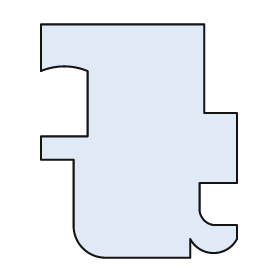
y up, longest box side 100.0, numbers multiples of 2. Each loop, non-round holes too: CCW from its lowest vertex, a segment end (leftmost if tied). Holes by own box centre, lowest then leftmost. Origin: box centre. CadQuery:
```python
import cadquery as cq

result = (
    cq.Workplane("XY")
    .moveTo(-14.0, -50.0)
    .lineTo(22.0, -50.0)
    .lineTo(22.0, -42.0)
    .threePointArc((32.0, -48.0), (42.0, -42.0))
    .lineTo(42.0, -36.0)
    .lineTo(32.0, -36.0)
    .threePointArc((28.0, -34.0), (26.0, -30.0))
    .lineTo(26.0, -18.0)
    .lineTo(42.0, -18.0)
    .lineTo(42.0, 12.0)
    .lineTo(28.0, 12.0)
    .lineTo(28.0, 50.0)
    .lineTo(-42.0, 50.0)
    .lineTo(-42.0, 30.0)
    .threePointArc((-32.0, 32.0), (-22.0, 30.0))
    .lineTo(-22.0, 2.0)
    .lineTo(-42.0, 2.0)
    .lineTo(-42.0, -8.0)
    .lineTo(-28.0, -8.0)
    .lineTo(-28.0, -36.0)
    .threePointArc((-24.0, -46.0), (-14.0, -50.0))
    .close()
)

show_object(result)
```